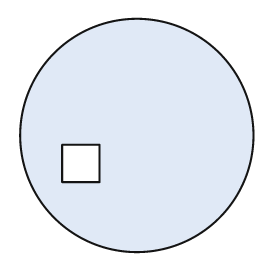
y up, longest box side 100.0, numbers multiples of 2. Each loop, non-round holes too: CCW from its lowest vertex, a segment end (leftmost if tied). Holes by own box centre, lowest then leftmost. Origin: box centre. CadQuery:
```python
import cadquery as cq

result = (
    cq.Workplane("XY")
    .moveTo(0.0, 0.0)
    .circle(50.0)
    .moveTo(-32.0, -20.0)
    .lineTo(-16.0, -20.0)
    .lineTo(-16.0, -4.0)
    .lineTo(-32.0, -4.0)
    .close()
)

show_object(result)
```